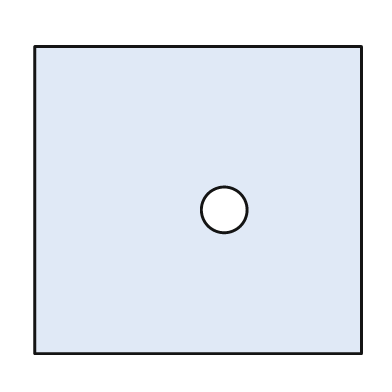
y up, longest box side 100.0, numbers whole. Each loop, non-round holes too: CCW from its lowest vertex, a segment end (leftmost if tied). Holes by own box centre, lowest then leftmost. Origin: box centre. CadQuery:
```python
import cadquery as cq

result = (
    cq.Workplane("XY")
    .moveTo(-50.0, -47.0)
    .lineTo(50.0, -47.0)
    .lineTo(50.0, 47.0)
    .lineTo(-50.0, 47.0)
    .close()
    .moveTo(8.0, -3.0)
    .circle(7.0)
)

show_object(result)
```